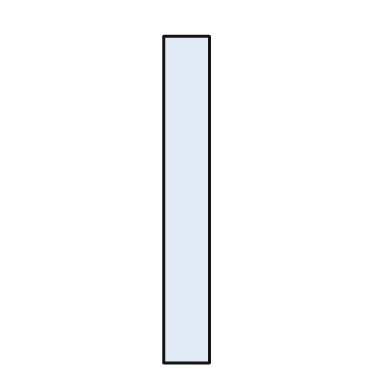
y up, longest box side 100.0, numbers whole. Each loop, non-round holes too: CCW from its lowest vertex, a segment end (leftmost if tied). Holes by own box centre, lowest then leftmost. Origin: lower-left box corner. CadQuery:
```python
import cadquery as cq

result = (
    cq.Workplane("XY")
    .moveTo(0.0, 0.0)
    .lineTo(14.0, 0.0)
    .lineTo(14.0, 100.0)
    .lineTo(0.0, 100.0)
    .close()
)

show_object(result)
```